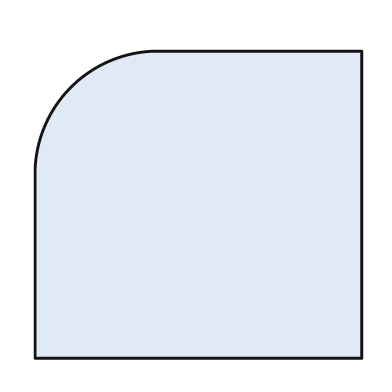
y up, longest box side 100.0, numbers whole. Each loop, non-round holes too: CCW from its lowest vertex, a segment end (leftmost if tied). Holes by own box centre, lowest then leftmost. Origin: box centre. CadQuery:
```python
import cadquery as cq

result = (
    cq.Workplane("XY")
    .moveTo(-50.0, -47.0)
    .lineTo(50.0, -47.0)
    .lineTo(50.0, 47.0)
    .lineTo(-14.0, 47.0)
    .threePointArc((-39.0, 36.0), (-50.0, 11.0))
    .close()
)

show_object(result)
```